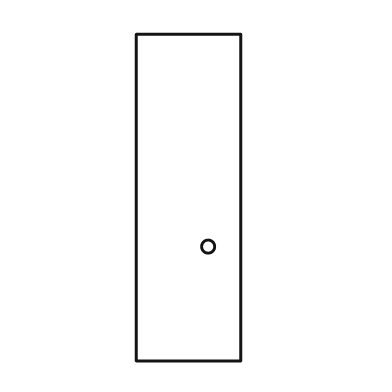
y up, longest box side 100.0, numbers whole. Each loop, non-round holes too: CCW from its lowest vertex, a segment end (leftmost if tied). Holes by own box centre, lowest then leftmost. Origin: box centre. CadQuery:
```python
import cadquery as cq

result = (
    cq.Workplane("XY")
    .moveTo(-16.0, -50.0)
    .lineTo(16.0, -50.0)
    .lineTo(16.0, 50.0)
    .lineTo(-16.0, 50.0)
    .close()
    .moveTo(6.0, -15.0)
    .circle(2.0)
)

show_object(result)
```